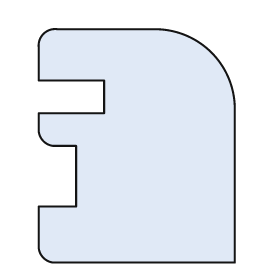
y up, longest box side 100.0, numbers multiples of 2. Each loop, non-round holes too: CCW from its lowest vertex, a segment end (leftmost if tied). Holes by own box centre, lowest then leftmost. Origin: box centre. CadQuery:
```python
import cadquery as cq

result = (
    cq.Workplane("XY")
    .moveTo(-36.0, -50.0)
    .lineTo(42.0, -50.0)
    .lineTo(42.0, 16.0)
    .threePointArc((32.0, 40.0), (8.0, 50.0))
    .lineTo(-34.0, 50.0)
    .threePointArc((-40.0, 48.0), (-42.0, 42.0))
    .lineTo(-42.0, 28.0)
    .lineTo(-14.0, 28.0)
    .lineTo(-14.0, 14.0)
    .lineTo(-42.0, 14.0)
    .lineTo(-42.0, 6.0)
    .threePointArc((-40.0, 2.0), (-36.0, 0.0))
    .lineTo(-26.0, 0.0)
    .lineTo(-26.0, -26.0)
    .lineTo(-42.0, -26.0)
    .lineTo(-42.0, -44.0)
    .threePointArc((-40.0, -48.0), (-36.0, -50.0))
    .close()
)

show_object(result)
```